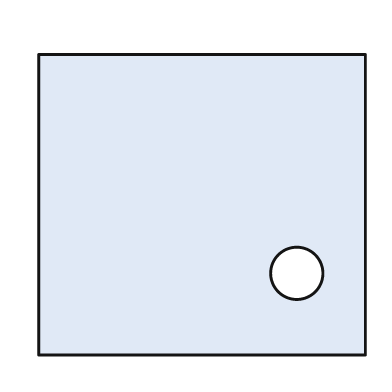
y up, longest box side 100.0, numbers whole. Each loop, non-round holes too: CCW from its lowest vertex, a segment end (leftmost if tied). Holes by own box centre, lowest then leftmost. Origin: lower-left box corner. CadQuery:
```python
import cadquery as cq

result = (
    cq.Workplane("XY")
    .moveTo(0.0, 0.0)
    .lineTo(100.0, 0.0)
    .lineTo(100.0, 92.0)
    .lineTo(0.0, 92.0)
    .close()
    .moveTo(79.0, 25.0)
    .circle(8.0)
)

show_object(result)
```